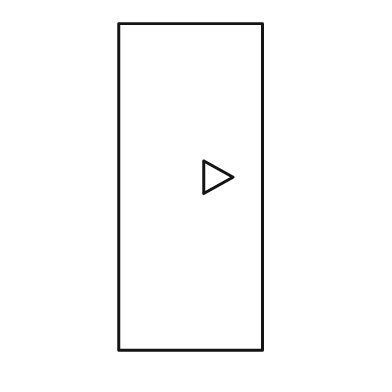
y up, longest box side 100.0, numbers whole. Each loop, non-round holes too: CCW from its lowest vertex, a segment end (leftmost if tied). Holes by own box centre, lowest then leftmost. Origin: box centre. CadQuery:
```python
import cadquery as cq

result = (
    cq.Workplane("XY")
    .moveTo(-22.0, -50.0)
    .lineTo(22.0, -50.0)
    .lineTo(22.0, 50.0)
    .lineTo(-22.0, 50.0)
    .close()
    .moveTo(4.0, -2.0)
    .lineTo(13.0, 3.0)
    .lineTo(4.0, 8.0)
    .close()
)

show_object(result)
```